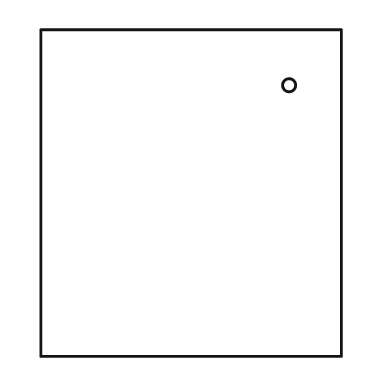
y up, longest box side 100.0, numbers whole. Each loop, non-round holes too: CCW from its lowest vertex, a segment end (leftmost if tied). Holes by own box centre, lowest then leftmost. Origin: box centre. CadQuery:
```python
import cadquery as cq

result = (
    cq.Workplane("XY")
    .moveTo(-46.0, -50.0)
    .lineTo(46.0, -50.0)
    .lineTo(46.0, 50.0)
    .lineTo(-46.0, 50.0)
    .close()
    .moveTo(30.0, 33.0)
    .circle(2.0)
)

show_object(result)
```